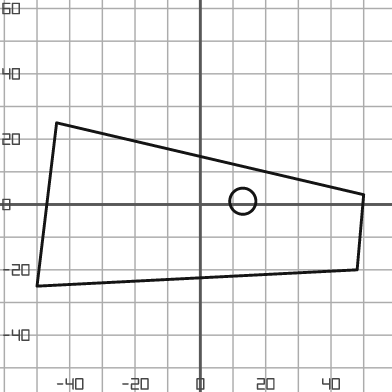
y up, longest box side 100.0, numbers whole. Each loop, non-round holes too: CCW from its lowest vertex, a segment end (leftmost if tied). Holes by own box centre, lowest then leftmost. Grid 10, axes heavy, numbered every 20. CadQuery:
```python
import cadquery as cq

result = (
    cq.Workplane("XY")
    .moveTo(-50.0, -25.0)
    .lineTo(48.0, -20.0)
    .lineTo(50.0, 3.0)
    .lineTo(-44.0, 25.0)
    .close()
    .moveTo(13.0, 1.0)
    .circle(4.0)
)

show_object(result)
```